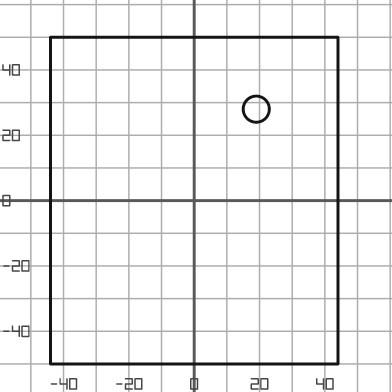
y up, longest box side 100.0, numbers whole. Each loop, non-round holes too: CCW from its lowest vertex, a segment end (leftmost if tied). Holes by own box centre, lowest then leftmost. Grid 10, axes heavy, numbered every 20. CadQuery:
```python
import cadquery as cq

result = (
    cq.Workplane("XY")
    .moveTo(-44.0, -50.0)
    .lineTo(44.0, -50.0)
    .lineTo(44.0, 50.0)
    .lineTo(-44.0, 50.0)
    .close()
    .moveTo(19.0, 28.0)
    .circle(4.0)
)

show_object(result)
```